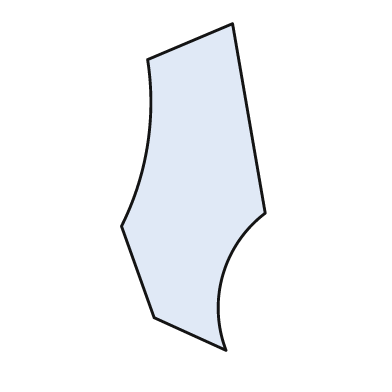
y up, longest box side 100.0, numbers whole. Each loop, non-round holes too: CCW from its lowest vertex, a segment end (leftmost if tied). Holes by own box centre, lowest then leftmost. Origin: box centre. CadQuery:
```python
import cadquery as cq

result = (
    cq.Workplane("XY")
    .moveTo(10.0, -50.0)
    .threePointArc((9.0, -27.0), (22.0, -8.0))
    .lineTo(12.0, 50.0)
    .lineTo(-14.0, 39.0)
    .threePointArc((-14.0, 13.0), (-22.0, -12.0))
    .lineTo(-12.0, -40.0)
    .close()
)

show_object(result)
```